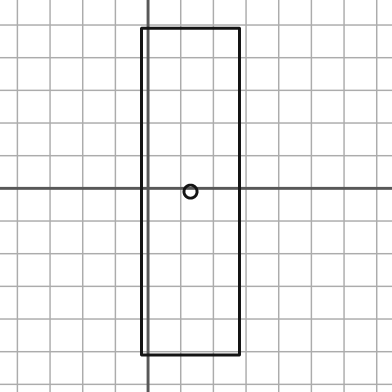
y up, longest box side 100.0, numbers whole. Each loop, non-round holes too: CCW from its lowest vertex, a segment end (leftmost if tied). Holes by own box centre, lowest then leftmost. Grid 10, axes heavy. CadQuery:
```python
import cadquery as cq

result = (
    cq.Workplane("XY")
    .moveTo(-2.0, -51.0)
    .lineTo(28.0, -51.0)
    .lineTo(28.0, 49.0)
    .lineTo(-2.0, 49.0)
    .close()
    .moveTo(13.0, -1.0)
    .circle(2.0)
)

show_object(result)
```